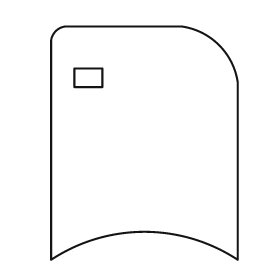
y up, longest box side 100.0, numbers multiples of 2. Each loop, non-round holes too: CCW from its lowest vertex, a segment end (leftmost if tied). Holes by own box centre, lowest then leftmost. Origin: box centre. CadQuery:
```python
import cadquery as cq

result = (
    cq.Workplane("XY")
    .moveTo(-40.0, -50.0)
    .threePointArc((0.0, -38.0), (40.0, -50.0))
    .lineTo(40.0, 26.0)
    .threePointArc((32.0, 42.0), (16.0, 50.0))
    .lineTo(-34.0, 50.0)
    .threePointArc((-38.0, 48.0), (-40.0, 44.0))
    .close()
    .moveTo(-30.0, 24.0)
    .lineTo(-18.0, 24.0)
    .lineTo(-18.0, 32.0)
    .lineTo(-30.0, 32.0)
    .close()
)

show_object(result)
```